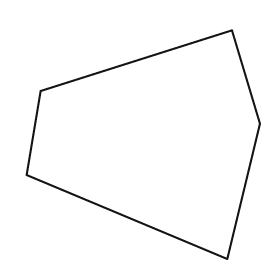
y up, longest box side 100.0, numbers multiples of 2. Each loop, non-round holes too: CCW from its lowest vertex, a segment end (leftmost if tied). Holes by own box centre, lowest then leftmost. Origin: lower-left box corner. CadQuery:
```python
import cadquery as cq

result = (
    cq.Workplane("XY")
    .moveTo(86.0, 0.0)
    .lineTo(100.0, 58.0)
    .lineTo(88.0, 98.0)
    .lineTo(6.0, 72.0)
    .lineTo(0.0, 36.0)
    .close()
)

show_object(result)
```